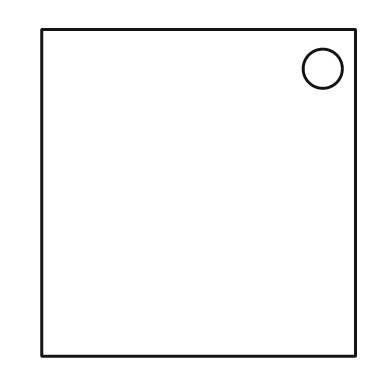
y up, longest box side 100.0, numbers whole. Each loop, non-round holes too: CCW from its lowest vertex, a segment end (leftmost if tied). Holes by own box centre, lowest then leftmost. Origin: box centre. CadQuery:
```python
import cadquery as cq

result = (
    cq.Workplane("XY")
    .moveTo(-48.0, -50.0)
    .lineTo(48.0, -50.0)
    .lineTo(48.0, 50.0)
    .lineTo(-48.0, 50.0)
    .close()
    .moveTo(38.0, 38.0)
    .circle(6.0)
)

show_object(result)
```